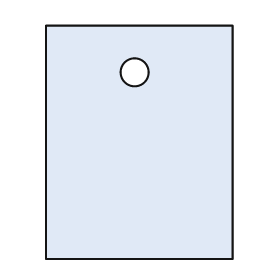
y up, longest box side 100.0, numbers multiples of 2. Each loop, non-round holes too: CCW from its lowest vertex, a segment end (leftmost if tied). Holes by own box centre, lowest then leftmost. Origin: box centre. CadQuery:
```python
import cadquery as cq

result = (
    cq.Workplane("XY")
    .moveTo(-40.0, -50.0)
    .lineTo(40.0, -50.0)
    .lineTo(40.0, 50.0)
    .lineTo(-40.0, 50.0)
    .close()
    .moveTo(-2.0, 30.0)
    .circle(6.0)
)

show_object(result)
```